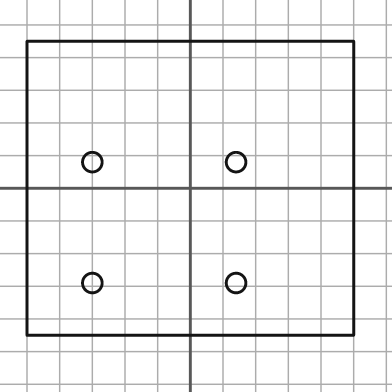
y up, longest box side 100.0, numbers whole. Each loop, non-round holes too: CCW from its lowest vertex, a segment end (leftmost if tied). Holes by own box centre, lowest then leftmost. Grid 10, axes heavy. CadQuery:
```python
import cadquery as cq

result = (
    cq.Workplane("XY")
    .moveTo(-50.0, -45.0)
    .lineTo(50.0, -45.0)
    .lineTo(50.0, 45.0)
    .lineTo(-50.0, 45.0)
    .close()
    .moveTo(-30.0, -29.0)
    .circle(3.0)
    .moveTo(14.0, -29.0)
    .circle(3.0)
    .moveTo(-30.0, 8.0)
    .circle(3.0)
    .moveTo(14.0, 8.0)
    .circle(3.0)
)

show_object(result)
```